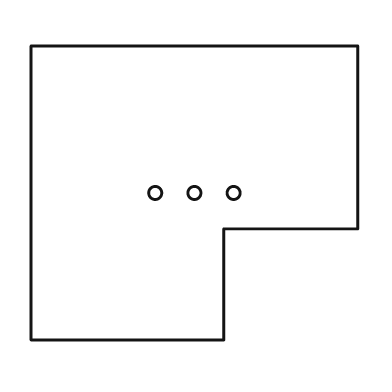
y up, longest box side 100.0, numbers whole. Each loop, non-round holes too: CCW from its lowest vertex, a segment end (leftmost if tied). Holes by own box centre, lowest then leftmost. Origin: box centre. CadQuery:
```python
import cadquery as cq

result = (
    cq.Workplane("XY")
    .moveTo(-50.0, -45.0)
    .lineTo(9.0, -45.0)
    .lineTo(9.0, -11.0)
    .lineTo(50.0, -11.0)
    .lineTo(50.0, 45.0)
    .lineTo(-50.0, 45.0)
    .close()
    .moveTo(-12.0, 0.0)
    .circle(2.0)
    .moveTo(0.0, 0.0)
    .circle(2.0)
    .moveTo(12.0, 0.0)
    .circle(2.0)
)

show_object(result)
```